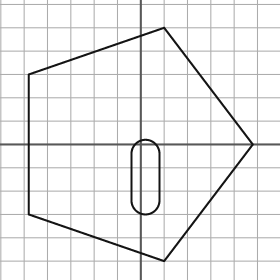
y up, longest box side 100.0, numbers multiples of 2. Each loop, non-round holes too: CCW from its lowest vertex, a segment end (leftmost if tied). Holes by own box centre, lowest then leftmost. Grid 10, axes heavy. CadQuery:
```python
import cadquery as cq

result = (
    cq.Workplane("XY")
    .moveTo(10.0, -50.0)
    .lineTo(48.0, 0.0)
    .lineTo(10.0, 50.0)
    .lineTo(-48.0, 30.0)
    .lineTo(-48.0, -30.0)
    .close()
    .moveTo(-4.0, -24.0)
    .threePointArc((2.0, -30.0), (8.0, -24.0))
    .lineTo(8.0, -4.0)
    .threePointArc((2.0, 2.0), (-4.0, -4.0))
    .close()
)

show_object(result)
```